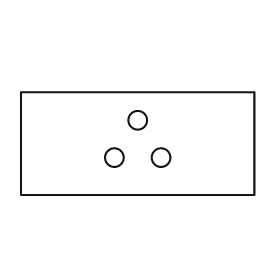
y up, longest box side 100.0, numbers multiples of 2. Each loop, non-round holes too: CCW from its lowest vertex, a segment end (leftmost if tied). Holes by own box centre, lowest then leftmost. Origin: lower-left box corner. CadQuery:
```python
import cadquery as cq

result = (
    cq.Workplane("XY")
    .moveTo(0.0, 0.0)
    .lineTo(100.0, 0.0)
    .lineTo(100.0, 44.0)
    .lineTo(0.0, 44.0)
    .close()
    .moveTo(40.0, 16.0)
    .circle(4.0)
    .moveTo(60.0, 16.0)
    .circle(4.0)
    .moveTo(50.0, 32.0)
    .circle(4.0)
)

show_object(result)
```